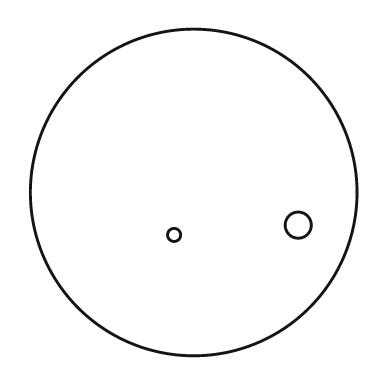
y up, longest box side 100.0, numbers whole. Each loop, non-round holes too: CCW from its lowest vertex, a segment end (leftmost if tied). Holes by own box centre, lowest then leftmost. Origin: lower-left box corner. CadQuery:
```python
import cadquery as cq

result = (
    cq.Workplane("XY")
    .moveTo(50.0, 50.0)
    .circle(50.0)
    .moveTo(44.0, 37.0)
    .circle(2.0)
    .moveTo(82.0, 40.0)
    .circle(4.0)
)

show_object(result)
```